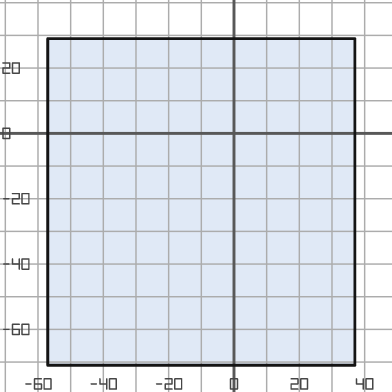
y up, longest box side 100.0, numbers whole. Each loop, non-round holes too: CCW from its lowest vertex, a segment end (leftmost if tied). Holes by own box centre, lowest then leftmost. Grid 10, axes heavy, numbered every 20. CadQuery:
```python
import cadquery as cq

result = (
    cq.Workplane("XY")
    .moveTo(-57.0, -71.0)
    .lineTo(37.0, -71.0)
    .lineTo(37.0, 29.0)
    .lineTo(-57.0, 29.0)
    .close()
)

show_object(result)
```